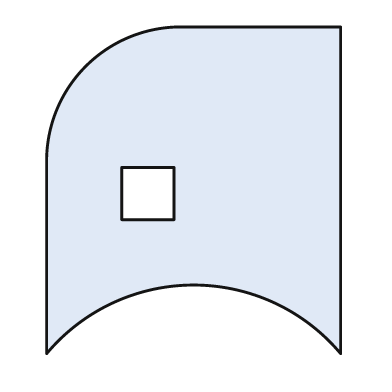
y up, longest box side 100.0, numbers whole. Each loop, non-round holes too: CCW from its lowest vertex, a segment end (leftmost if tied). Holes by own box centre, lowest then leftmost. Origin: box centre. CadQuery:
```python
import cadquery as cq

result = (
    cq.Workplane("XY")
    .moveTo(-45.0, -50.0)
    .threePointArc((0.0, -29.0), (45.0, -50.0))
    .lineTo(45.0, 50.0)
    .lineTo(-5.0, 50.0)
    .threePointArc((-33.0, 38.0), (-45.0, 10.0))
    .close()
    .moveTo(-22.0, -9.0)
    .lineTo(-6.0, -9.0)
    .lineTo(-6.0, 7.0)
    .lineTo(-22.0, 7.0)
    .close()
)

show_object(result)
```